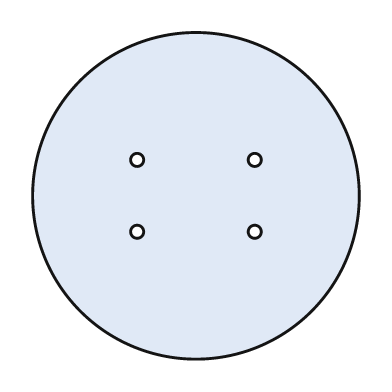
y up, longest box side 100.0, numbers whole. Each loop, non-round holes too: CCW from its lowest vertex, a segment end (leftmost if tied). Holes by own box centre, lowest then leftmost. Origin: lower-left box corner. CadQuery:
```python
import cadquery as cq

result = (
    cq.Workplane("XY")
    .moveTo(50.0, 50.0)
    .circle(50.0)
    .moveTo(32.0, 39.0)
    .circle(2.0)
    .moveTo(68.0, 39.0)
    .circle(2.0)
    .moveTo(32.0, 61.0)
    .circle(2.0)
    .moveTo(68.0, 61.0)
    .circle(2.0)
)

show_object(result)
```